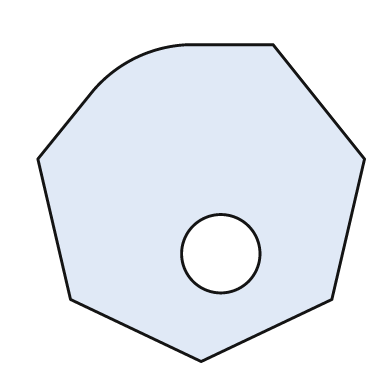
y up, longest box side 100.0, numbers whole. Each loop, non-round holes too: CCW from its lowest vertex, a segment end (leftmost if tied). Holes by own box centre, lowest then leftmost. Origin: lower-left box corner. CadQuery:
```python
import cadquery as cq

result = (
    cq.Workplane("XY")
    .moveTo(50.0, 0.0)
    .lineTo(90.0, 19.0)
    .lineTo(100.0, 62.0)
    .lineTo(72.0, 97.0)
    .lineTo(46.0, 97.0)
    .threePointArc((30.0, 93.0), (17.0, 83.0))
    .lineTo(0.0, 62.0)
    .lineTo(10.0, 19.0)
    .close()
    .moveTo(56.0, 33.0)
    .circle(12.0)
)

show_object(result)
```